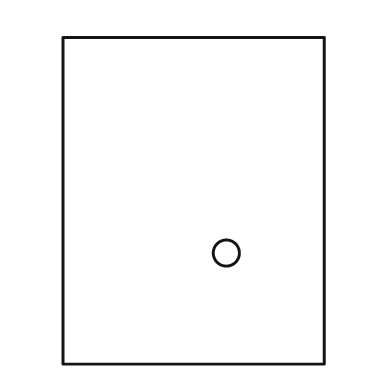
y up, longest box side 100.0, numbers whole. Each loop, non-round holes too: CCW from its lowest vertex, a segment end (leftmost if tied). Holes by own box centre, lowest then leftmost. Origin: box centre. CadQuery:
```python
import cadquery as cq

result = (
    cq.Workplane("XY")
    .moveTo(-40.0, -50.0)
    .lineTo(40.0, -50.0)
    .lineTo(40.0, 50.0)
    .lineTo(-40.0, 50.0)
    .close()
    .moveTo(10.0, -16.0)
    .circle(4.0)
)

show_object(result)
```